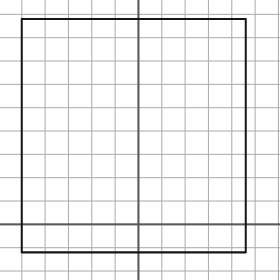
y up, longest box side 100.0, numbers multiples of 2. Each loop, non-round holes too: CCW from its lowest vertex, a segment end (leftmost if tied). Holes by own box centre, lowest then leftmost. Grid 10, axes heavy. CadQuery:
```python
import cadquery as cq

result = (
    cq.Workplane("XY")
    .moveTo(-50.0, -12.0)
    .lineTo(46.0, -12.0)
    .lineTo(46.0, 88.0)
    .lineTo(-50.0, 88.0)
    .close()
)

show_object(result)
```